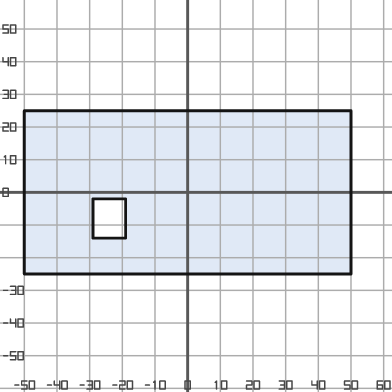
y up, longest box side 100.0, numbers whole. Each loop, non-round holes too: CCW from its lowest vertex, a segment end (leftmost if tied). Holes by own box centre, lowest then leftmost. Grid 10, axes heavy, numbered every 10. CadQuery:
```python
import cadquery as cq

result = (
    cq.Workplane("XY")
    .moveTo(-50.0, -25.0)
    .lineTo(50.0, -25.0)
    .lineTo(50.0, 25.0)
    .lineTo(-50.0, 25.0)
    .close()
    .moveTo(-29.0, -14.0)
    .lineTo(-19.0, -14.0)
    .lineTo(-19.0, -2.0)
    .lineTo(-29.0, -2.0)
    .close()
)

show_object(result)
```